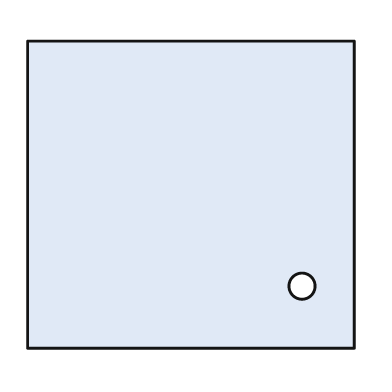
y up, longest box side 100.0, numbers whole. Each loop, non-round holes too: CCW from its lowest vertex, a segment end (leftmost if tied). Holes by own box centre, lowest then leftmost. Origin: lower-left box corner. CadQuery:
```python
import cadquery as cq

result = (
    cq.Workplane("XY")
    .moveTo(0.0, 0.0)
    .lineTo(100.0, 0.0)
    .lineTo(100.0, 94.0)
    .lineTo(0.0, 94.0)
    .close()
    .moveTo(84.0, 19.0)
    .circle(4.0)
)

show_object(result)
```